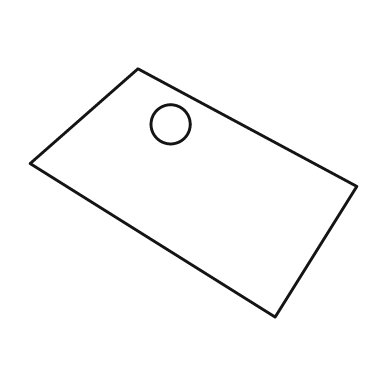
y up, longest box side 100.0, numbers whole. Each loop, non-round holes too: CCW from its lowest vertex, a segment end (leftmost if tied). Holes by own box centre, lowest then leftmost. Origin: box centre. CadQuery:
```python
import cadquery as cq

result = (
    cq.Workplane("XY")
    .moveTo(25.0, -38.0)
    .lineTo(50.0, 2.0)
    .lineTo(-17.0, 38.0)
    .lineTo(-50.0, 9.0)
    .close()
    .moveTo(-7.0, 21.0)
    .circle(6.0)
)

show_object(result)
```